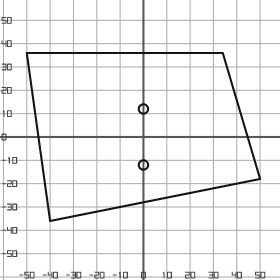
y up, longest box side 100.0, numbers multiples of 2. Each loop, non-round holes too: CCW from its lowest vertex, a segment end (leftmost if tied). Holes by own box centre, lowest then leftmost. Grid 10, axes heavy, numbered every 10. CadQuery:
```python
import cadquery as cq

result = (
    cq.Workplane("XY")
    .moveTo(-40.0, -36.0)
    .lineTo(50.0, -18.0)
    .lineTo(34.0, 36.0)
    .lineTo(-50.0, 36.0)
    .close()
    .moveTo(0.0, -12.0)
    .circle(2.0)
    .moveTo(0.0, 12.0)
    .circle(2.0)
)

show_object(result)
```